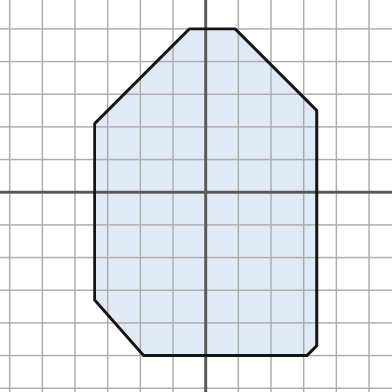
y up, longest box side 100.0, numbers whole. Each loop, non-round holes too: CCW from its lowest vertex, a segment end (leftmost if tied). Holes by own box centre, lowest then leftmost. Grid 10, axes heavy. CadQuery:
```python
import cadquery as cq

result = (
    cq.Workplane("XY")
    .moveTo(-19.0, -50.0)
    .lineTo(31.0, -50.0)
    .lineTo(34.0, -47.0)
    .lineTo(34.0, 25.0)
    .lineTo(9.0, 50.0)
    .lineTo(-5.0, 50.0)
    .lineTo(-34.0, 21.0)
    .lineTo(-34.0, -33.0)
    .close()
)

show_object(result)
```